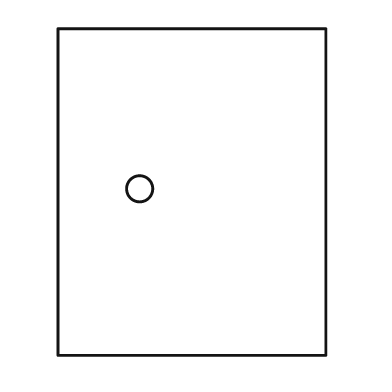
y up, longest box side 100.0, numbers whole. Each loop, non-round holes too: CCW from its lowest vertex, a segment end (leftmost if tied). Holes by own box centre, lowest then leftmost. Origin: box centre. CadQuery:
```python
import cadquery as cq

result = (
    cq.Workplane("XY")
    .moveTo(-41.0, -50.0)
    .lineTo(41.0, -50.0)
    .lineTo(41.0, 50.0)
    .lineTo(-41.0, 50.0)
    .close()
    .moveTo(-16.0, 1.0)
    .circle(4.0)
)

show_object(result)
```